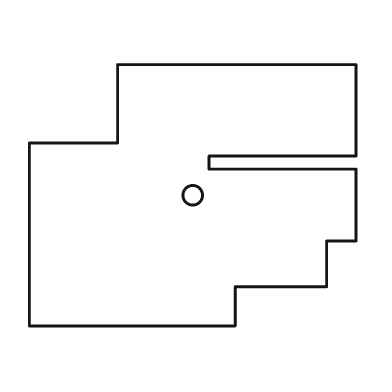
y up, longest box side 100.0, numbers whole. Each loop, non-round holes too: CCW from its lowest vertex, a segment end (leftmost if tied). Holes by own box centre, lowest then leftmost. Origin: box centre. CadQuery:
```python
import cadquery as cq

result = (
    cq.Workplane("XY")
    .moveTo(-50.0, -40.0)
    .lineTo(13.0, -40.0)
    .lineTo(13.0, -28.0)
    .lineTo(41.0, -28.0)
    .lineTo(41.0, -14.0)
    .lineTo(50.0, -14.0)
    .lineTo(50.0, 8.0)
    .lineTo(5.0, 8.0)
    .lineTo(5.0, 12.0)
    .lineTo(50.0, 12.0)
    .lineTo(50.0, 40.0)
    .lineTo(-23.0, 40.0)
    .lineTo(-23.0, 16.0)
    .lineTo(-50.0, 16.0)
    .close()
    .moveTo(0.0, 0.0)
    .circle(3.0)
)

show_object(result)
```